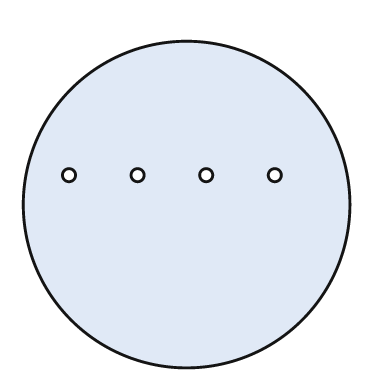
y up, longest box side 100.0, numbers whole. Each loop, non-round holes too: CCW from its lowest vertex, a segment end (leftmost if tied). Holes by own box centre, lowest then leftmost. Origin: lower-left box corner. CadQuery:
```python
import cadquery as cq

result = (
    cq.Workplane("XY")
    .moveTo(50.0, 50.0)
    .circle(50.0)
    .moveTo(14.0, 59.0)
    .circle(2.0)
    .moveTo(35.0, 59.0)
    .circle(2.0)
    .moveTo(56.0, 59.0)
    .circle(2.0)
    .moveTo(77.0, 59.0)
    .circle(2.0)
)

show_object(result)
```